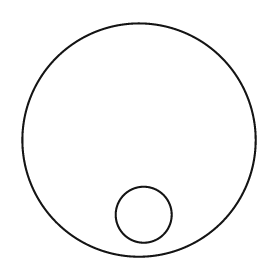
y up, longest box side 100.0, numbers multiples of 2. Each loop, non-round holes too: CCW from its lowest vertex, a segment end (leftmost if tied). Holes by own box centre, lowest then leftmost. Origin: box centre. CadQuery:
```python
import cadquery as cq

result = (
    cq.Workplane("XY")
    .moveTo(0.0, 0.0)
    .circle(50.0)
    .moveTo(2.0, -32.0)
    .circle(12.0)
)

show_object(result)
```